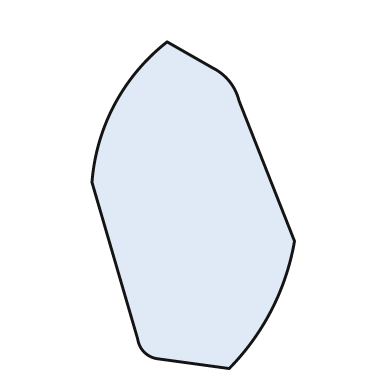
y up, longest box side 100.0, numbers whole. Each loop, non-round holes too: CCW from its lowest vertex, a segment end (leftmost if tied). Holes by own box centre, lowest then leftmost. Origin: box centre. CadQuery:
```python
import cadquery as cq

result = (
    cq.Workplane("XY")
    .moveTo(11.0, -50.0)
    .threePointArc((24.0, -32.0), (31.0, -11.0))
    .lineTo(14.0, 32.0)
    .threePointArc((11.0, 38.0), (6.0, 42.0))
    .lineTo(-8.0, 50.0)
    .threePointArc((-24.0, 31.0), (-31.0, 7.0))
    .lineTo(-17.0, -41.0)
    .threePointArc((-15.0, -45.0), (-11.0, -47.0))
    .close()
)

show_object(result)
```